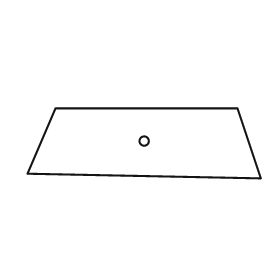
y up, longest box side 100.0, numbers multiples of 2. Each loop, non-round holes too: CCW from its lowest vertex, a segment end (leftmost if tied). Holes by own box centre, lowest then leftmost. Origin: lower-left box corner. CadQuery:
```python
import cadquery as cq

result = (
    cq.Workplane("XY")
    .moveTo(100.0, 0.0)
    .lineTo(90.0, 30.0)
    .lineTo(12.0, 30.0)
    .lineTo(0.0, 2.0)
    .close()
    .moveTo(50.0, 16.0)
    .circle(2.0)
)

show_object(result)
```